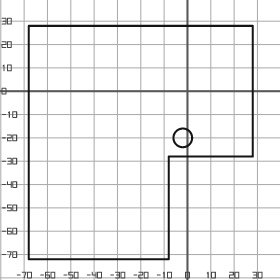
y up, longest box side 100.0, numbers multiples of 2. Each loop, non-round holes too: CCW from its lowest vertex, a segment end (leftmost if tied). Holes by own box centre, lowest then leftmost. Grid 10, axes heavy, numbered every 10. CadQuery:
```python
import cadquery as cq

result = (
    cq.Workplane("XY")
    .moveTo(-68.0, -72.0)
    .lineTo(-8.0, -72.0)
    .lineTo(-8.0, -28.0)
    .lineTo(28.0, -28.0)
    .lineTo(28.0, 28.0)
    .lineTo(-68.0, 28.0)
    .close()
    .moveTo(-2.0, -20.0)
    .circle(4.0)
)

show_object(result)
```